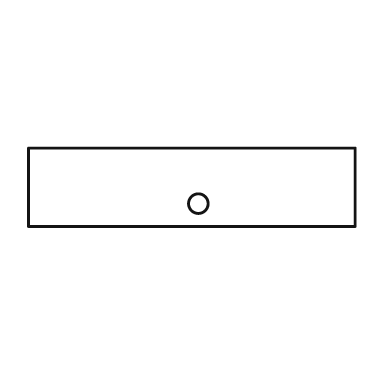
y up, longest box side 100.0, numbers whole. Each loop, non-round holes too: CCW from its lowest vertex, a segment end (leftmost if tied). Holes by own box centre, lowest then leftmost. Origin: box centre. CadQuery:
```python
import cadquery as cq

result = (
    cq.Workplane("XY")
    .moveTo(-50.0, -12.0)
    .lineTo(50.0, -12.0)
    .lineTo(50.0, 12.0)
    .lineTo(-50.0, 12.0)
    .close()
    .moveTo(2.0, -5.0)
    .circle(3.0)
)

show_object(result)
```